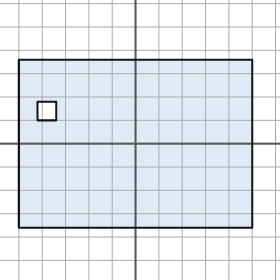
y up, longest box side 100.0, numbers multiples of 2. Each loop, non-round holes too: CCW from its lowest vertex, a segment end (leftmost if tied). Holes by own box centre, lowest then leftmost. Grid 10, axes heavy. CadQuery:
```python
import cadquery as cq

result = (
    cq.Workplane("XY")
    .moveTo(-50.0, -36.0)
    .lineTo(50.0, -36.0)
    .lineTo(50.0, 36.0)
    .lineTo(-50.0, 36.0)
    .close()
    .moveTo(-42.0, 10.0)
    .lineTo(-34.0, 10.0)
    .lineTo(-34.0, 18.0)
    .lineTo(-42.0, 18.0)
    .close()
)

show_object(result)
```